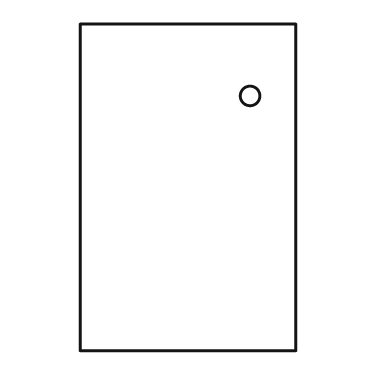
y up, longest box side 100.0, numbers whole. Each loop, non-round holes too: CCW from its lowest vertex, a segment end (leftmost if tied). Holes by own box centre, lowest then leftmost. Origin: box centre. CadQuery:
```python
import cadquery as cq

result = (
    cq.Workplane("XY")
    .moveTo(-33.0, -50.0)
    .lineTo(33.0, -50.0)
    .lineTo(33.0, 50.0)
    .lineTo(-33.0, 50.0)
    .close()
    .moveTo(19.0, 28.0)
    .circle(3.0)
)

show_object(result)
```